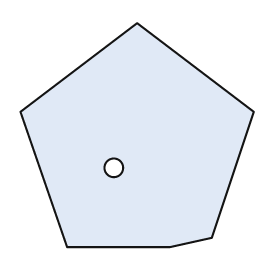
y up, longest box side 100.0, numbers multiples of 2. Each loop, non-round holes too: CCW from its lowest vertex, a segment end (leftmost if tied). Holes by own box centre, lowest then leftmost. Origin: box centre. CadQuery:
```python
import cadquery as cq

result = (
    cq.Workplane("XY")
    .moveTo(-30.0, -48.0)
    .lineTo(14.0, -48.0)
    .lineTo(32.0, -44.0)
    .lineTo(50.0, 10.0)
    .lineTo(0.0, 48.0)
    .lineTo(-50.0, 10.0)
    .close()
    .moveTo(-10.0, -14.0)
    .circle(4.0)
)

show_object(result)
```